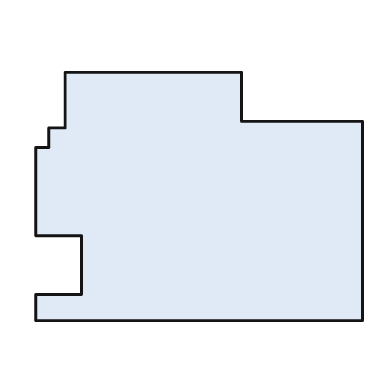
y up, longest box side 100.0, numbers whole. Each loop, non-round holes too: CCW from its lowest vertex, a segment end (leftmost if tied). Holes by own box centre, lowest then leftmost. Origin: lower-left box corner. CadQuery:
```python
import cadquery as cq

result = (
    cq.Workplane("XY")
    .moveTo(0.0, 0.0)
    .lineTo(100.0, 0.0)
    .lineTo(100.0, 61.0)
    .lineTo(63.0, 61.0)
    .lineTo(63.0, 76.0)
    .lineTo(9.0, 76.0)
    .lineTo(9.0, 59.0)
    .lineTo(4.0, 59.0)
    .lineTo(4.0, 53.0)
    .lineTo(0.0, 53.0)
    .lineTo(0.0, 26.0)
    .lineTo(14.0, 26.0)
    .lineTo(14.0, 8.0)
    .lineTo(0.0, 8.0)
    .close()
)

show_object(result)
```